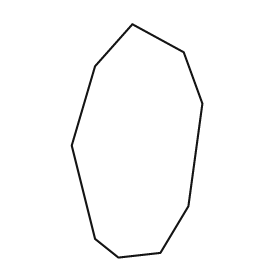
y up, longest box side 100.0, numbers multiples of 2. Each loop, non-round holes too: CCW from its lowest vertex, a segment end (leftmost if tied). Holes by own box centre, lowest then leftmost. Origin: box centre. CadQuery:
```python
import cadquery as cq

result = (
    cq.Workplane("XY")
    .moveTo(-8.0, -50.0)
    .lineTo(10.0, -48.0)
    .lineTo(22.0, -28.0)
    .lineTo(28.0, 16.0)
    .lineTo(20.0, 38.0)
    .lineTo(-2.0, 50.0)
    .lineTo(-18.0, 32.0)
    .lineTo(-28.0, -2.0)
    .lineTo(-18.0, -42.0)
    .close()
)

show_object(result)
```